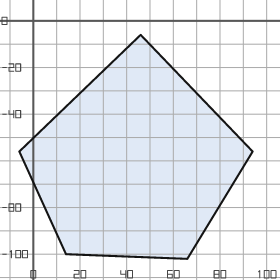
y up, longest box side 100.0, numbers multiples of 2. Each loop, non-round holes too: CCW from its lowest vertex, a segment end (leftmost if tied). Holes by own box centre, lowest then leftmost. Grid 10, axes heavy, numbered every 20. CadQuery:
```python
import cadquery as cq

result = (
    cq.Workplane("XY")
    .moveTo(66.0, -102.0)
    .lineTo(94.0, -56.0)
    .lineTo(46.0, -6.0)
    .lineTo(-6.0, -56.0)
    .lineTo(14.0, -100.0)
    .close()
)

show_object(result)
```